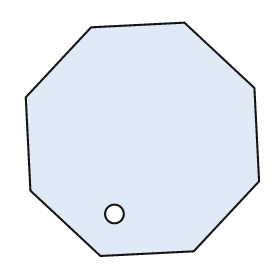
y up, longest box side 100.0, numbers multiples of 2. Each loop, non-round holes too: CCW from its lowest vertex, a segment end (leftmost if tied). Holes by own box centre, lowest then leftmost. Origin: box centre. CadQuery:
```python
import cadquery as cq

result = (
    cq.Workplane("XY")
    .moveTo(-18.0, -50.0)
    .lineTo(22.0, -48.0)
    .lineTo(50.0, -18.0)
    .lineTo(48.0, 22.0)
    .lineTo(18.0, 50.0)
    .lineTo(-22.0, 48.0)
    .lineTo(-50.0, 18.0)
    .lineTo(-48.0, -22.0)
    .close()
    .moveTo(-12.0, -32.0)
    .circle(4.0)
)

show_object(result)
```